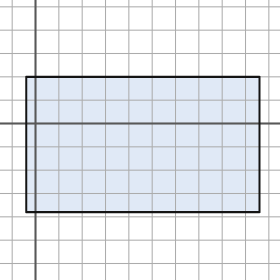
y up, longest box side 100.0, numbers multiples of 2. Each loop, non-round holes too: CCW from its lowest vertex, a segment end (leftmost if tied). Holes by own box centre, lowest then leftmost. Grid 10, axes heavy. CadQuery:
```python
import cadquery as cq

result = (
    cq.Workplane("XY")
    .moveTo(-4.0, -38.0)
    .lineTo(96.0, -38.0)
    .lineTo(96.0, 20.0)
    .lineTo(-4.0, 20.0)
    .close()
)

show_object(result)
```